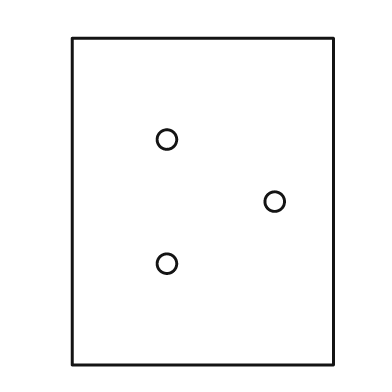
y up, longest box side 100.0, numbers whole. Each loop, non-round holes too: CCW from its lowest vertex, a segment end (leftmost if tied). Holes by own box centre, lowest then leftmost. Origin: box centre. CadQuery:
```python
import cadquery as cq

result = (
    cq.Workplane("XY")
    .moveTo(-40.0, -50.0)
    .lineTo(40.0, -50.0)
    .lineTo(40.0, 50.0)
    .lineTo(-40.0, 50.0)
    .close()
    .moveTo(-11.0, -19.0)
    .circle(3.0)
    .moveTo(22.0, 0.0)
    .circle(3.0)
    .moveTo(-11.0, 19.0)
    .circle(3.0)
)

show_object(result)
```